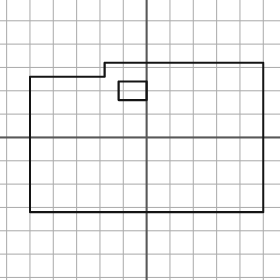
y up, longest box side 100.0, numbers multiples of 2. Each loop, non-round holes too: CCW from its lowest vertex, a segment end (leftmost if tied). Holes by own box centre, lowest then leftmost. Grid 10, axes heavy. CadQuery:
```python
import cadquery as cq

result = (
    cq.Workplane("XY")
    .moveTo(-50.0, -32.0)
    .lineTo(50.0, -32.0)
    .lineTo(50.0, 32.0)
    .lineTo(-18.0, 32.0)
    .lineTo(-18.0, 26.0)
    .lineTo(-50.0, 26.0)
    .close()
    .moveTo(-12.0, 16.0)
    .lineTo(0.0, 16.0)
    .lineTo(0.0, 24.0)
    .lineTo(-12.0, 24.0)
    .close()
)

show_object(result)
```